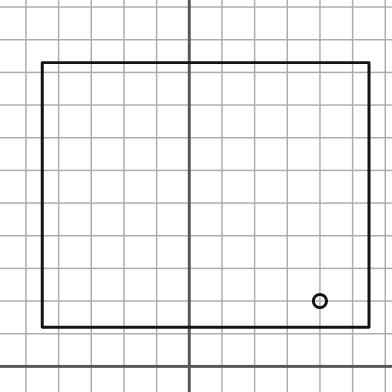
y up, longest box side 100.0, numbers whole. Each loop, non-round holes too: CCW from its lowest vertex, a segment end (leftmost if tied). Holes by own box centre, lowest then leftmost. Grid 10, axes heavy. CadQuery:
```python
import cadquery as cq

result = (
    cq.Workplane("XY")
    .moveTo(-45.0, 12.0)
    .lineTo(55.0, 12.0)
    .lineTo(55.0, 93.0)
    .lineTo(-45.0, 93.0)
    .close()
    .moveTo(40.0, 20.0)
    .circle(2.0)
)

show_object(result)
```